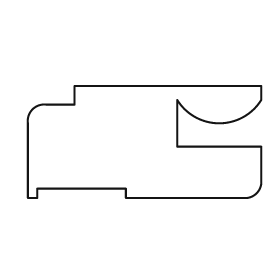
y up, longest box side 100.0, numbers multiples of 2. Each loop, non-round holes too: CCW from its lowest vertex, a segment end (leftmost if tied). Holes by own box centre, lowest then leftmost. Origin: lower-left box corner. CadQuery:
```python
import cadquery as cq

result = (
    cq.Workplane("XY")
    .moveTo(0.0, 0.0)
    .lineTo(4.0, 0.0)
    .lineTo(4.0, 4.0)
    .lineTo(42.0, 4.0)
    .lineTo(42.0, 0.0)
    .lineTo(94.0, 0.0)
    .threePointArc((98.0, 2.0), (100.0, 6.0))
    .lineTo(100.0, 22.0)
    .lineTo(64.0, 22.0)
    .lineTo(64.0, 42.0)
    .threePointArc((82.0, 32.0), (100.0, 42.0))
    .lineTo(100.0, 48.0)
    .lineTo(20.0, 48.0)
    .lineTo(20.0, 40.0)
    .lineTo(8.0, 40.0)
    .threePointArc((2.0, 38.0), (0.0, 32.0))
    .close()
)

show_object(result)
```